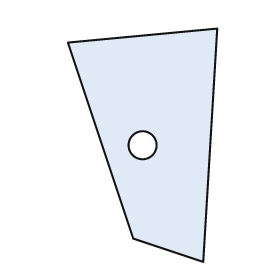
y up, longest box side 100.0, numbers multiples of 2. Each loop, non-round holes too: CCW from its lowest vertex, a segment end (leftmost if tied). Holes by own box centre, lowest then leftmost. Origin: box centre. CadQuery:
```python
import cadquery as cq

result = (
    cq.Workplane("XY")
    .moveTo(26.0, -50.0)
    .lineTo(32.0, 50.0)
    .lineTo(-32.0, 44.0)
    .lineTo(-4.0, -40.0)
    .close()
    .moveTo(0.0, 0.0)
    .circle(6.0)
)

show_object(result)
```